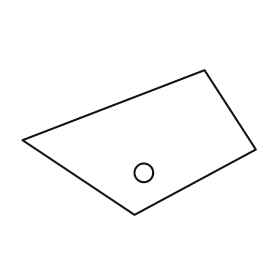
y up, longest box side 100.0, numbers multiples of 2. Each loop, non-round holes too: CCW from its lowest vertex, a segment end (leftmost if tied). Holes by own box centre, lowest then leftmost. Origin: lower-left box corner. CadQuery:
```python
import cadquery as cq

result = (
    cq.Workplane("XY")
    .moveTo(48.0, 0.0)
    .lineTo(100.0, 28.0)
    .lineTo(78.0, 62.0)
    .lineTo(0.0, 32.0)
    .close()
    .moveTo(52.0, 18.0)
    .circle(4.0)
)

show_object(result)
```